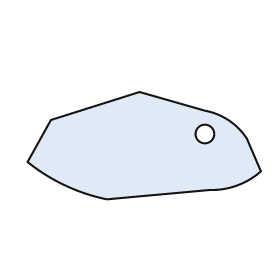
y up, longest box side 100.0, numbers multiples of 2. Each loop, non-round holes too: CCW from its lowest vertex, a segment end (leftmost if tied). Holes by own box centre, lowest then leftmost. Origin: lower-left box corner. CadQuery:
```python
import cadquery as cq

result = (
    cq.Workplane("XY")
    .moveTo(34.0, 0.0)
    .lineTo(78.0, 4.0)
    .threePointArc((90.0, 6.0), (100.0, 12.0))
    .lineTo(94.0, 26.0)
    .threePointArc((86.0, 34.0), (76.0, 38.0))
    .lineTo(48.0, 46.0)
    .lineTo(10.0, 34.0)
    .lineTo(0.0, 16.0)
    .threePointArc((16.0, 6.0), (34.0, 0.0))
    .close()
    .moveTo(76.0, 28.0)
    .circle(4.0)
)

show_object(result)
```